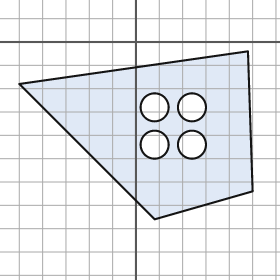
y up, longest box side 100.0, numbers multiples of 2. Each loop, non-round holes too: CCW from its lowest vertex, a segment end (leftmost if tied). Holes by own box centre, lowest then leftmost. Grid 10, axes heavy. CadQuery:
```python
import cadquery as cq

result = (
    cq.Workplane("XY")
    .moveTo(8.0, -76.0)
    .lineTo(50.0, -64.0)
    .lineTo(48.0, -4.0)
    .lineTo(-50.0, -18.0)
    .close()
    .moveTo(8.0, -44.0)
    .circle(6.0)
    .moveTo(24.0, -44.0)
    .circle(6.0)
    .moveTo(8.0, -28.0)
    .circle(6.0)
    .moveTo(24.0, -28.0)
    .circle(6.0)
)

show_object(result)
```